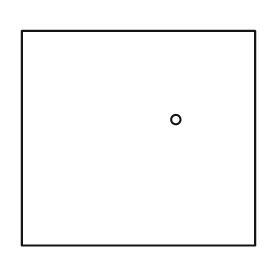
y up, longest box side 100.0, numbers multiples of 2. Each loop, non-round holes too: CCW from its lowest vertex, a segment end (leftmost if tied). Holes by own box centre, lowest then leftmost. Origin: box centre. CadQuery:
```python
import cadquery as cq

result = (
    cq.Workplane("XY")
    .moveTo(-50.0, -46.0)
    .lineTo(50.0, -46.0)
    .lineTo(50.0, 46.0)
    .lineTo(-50.0, 46.0)
    .close()
    .moveTo(16.0, 8.0)
    .circle(2.0)
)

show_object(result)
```